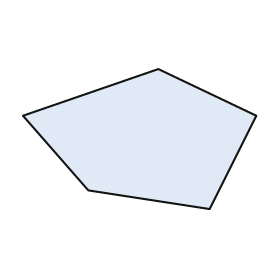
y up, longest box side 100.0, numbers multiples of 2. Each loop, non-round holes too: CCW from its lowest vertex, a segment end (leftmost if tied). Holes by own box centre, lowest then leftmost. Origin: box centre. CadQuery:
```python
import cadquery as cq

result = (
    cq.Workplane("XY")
    .moveTo(30.0, -30.0)
    .lineTo(50.0, 10.0)
    .lineTo(8.0, 30.0)
    .lineTo(-50.0, 10.0)
    .lineTo(-22.0, -22.0)
    .close()
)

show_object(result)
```